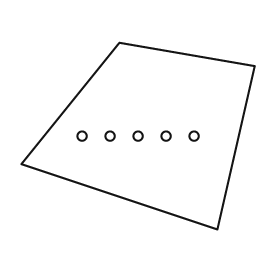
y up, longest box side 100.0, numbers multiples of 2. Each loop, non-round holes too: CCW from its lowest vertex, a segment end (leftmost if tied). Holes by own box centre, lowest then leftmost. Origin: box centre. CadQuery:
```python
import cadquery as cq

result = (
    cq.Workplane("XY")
    .moveTo(34.0, -40.0)
    .lineTo(50.0, 30.0)
    .lineTo(-8.0, 40.0)
    .lineTo(-50.0, -12.0)
    .close()
    .moveTo(-24.0, 0.0)
    .circle(2.0)
    .moveTo(-12.0, 0.0)
    .circle(2.0)
    .moveTo(0.0, 0.0)
    .circle(2.0)
    .moveTo(12.0, 0.0)
    .circle(2.0)
    .moveTo(24.0, 0.0)
    .circle(2.0)
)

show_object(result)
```